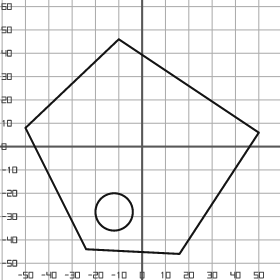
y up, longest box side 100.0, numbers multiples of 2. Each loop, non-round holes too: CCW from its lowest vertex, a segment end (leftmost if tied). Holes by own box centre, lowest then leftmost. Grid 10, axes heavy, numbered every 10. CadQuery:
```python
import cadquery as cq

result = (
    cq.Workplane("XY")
    .moveTo(16.0, -46.0)
    .lineTo(50.0, 6.0)
    .lineTo(-10.0, 46.0)
    .lineTo(-50.0, 8.0)
    .lineTo(-24.0, -44.0)
    .close()
    .moveTo(-12.0, -28.0)
    .circle(8.0)
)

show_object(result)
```